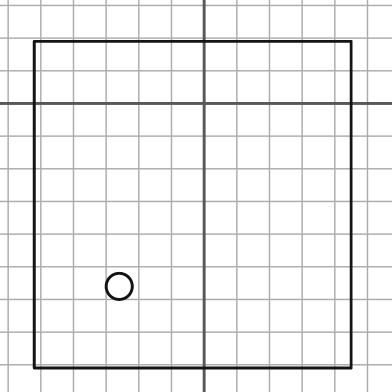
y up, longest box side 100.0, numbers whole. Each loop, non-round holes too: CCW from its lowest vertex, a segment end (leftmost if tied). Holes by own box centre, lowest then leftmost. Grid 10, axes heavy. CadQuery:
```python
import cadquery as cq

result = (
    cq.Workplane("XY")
    .moveTo(-52.0, -81.0)
    .lineTo(45.0, -81.0)
    .lineTo(45.0, 19.0)
    .lineTo(-52.0, 19.0)
    .close()
    .moveTo(-26.0, -56.0)
    .circle(4.0)
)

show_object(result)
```